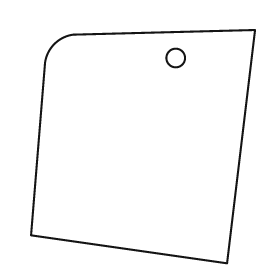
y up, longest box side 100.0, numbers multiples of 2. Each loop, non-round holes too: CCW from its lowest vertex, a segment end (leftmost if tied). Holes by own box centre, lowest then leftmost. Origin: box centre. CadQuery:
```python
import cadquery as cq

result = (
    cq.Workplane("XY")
    .moveTo(36.0, -50.0)
    .lineTo(48.0, 50.0)
    .lineTo(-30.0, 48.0)
    .threePointArc((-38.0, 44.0), (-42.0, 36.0))
    .lineTo(-48.0, -38.0)
    .close()
    .moveTo(14.0, 38.0)
    .circle(4.0)
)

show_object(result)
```